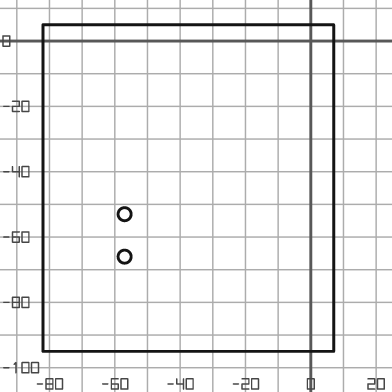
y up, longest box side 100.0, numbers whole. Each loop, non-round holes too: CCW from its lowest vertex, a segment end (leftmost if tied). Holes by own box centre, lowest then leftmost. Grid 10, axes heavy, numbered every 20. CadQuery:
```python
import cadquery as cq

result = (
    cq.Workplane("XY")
    .moveTo(-82.0, -95.0)
    .lineTo(7.0, -95.0)
    .lineTo(7.0, 5.0)
    .lineTo(-82.0, 5.0)
    .close()
    .moveTo(-57.0, -66.0)
    .circle(2.0)
    .moveTo(-57.0, -53.0)
    .circle(2.0)
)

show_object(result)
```